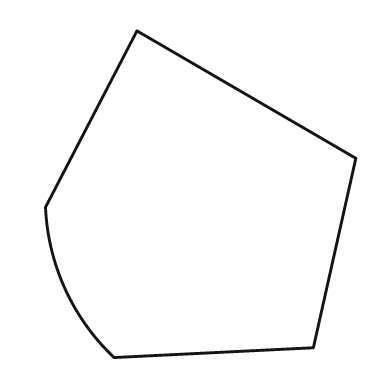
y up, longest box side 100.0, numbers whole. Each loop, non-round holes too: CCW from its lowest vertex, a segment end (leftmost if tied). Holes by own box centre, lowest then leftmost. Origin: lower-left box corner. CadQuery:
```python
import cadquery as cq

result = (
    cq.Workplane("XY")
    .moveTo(21.0, 0.0)
    .lineTo(82.0, 3.0)
    .lineTo(95.0, 61.0)
    .lineTo(28.0, 100.0)
    .lineTo(0.0, 46.0)
    .threePointArc((6.0, 21.0), (21.0, 0.0))
    .close()
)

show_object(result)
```